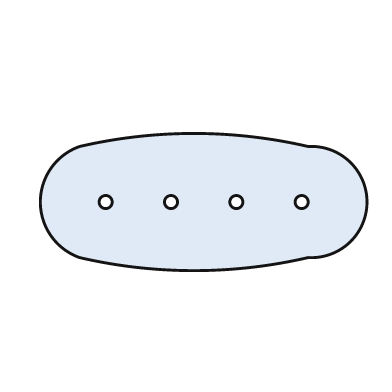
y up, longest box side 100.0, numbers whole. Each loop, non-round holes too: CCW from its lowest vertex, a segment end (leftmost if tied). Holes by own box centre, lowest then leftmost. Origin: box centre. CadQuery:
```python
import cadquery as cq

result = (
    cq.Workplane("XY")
    .moveTo(-38.0, -17.0)
    .threePointArc((-3.0, -21.0), (32.0, -17.0))
    .threePointArc((50.0, 0.0), (32.0, 17.0))
    .threePointArc((-3.0, 21.0), (-38.0, 17.0))
    .threePointArc((-50.0, 0.0), (-38.0, -17.0))
    .close()
    .moveTo(-30.0, 0.0)
    .circle(2.0)
    .moveTo(-10.0, 0.0)
    .circle(2.0)
    .moveTo(10.0, 0.0)
    .circle(2.0)
    .moveTo(30.0, 0.0)
    .circle(2.0)
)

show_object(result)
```